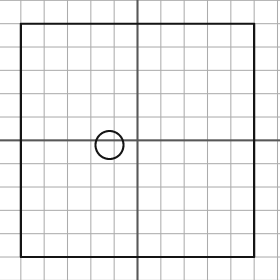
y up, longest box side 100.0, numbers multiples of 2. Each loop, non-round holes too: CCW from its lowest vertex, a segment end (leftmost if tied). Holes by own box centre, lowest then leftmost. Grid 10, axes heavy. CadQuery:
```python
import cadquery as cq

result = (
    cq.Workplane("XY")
    .moveTo(-50.0, -50.0)
    .lineTo(50.0, -50.0)
    .lineTo(50.0, 50.0)
    .lineTo(-50.0, 50.0)
    .close()
    .moveTo(-12.0, -2.0)
    .circle(6.0)
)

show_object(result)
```